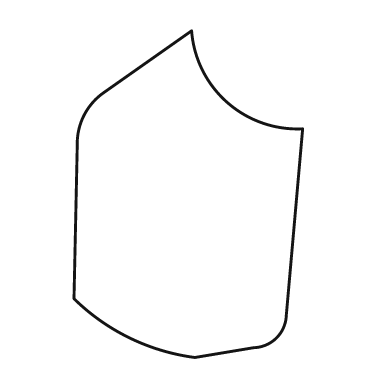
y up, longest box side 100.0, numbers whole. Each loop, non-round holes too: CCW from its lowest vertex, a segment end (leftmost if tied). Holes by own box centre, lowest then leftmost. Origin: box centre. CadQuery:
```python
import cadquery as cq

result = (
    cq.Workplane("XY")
    .moveTo(2.0, -50.0)
    .lineTo(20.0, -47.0)
    .threePointArc((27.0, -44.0), (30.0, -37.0))
    .lineTo(35.0, 20.0)
    .threePointArc((12.0, 28.0), (1.0, 50.0))
    .lineTo(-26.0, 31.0)
    .threePointArc((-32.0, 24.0), (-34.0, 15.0))
    .lineTo(-35.0, -32.0)
    .threePointArc((-18.0, -44.0), (2.0, -50.0))
    .close()
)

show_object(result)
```